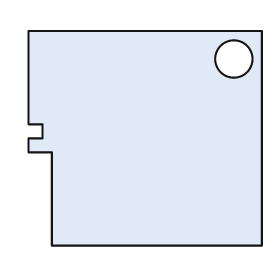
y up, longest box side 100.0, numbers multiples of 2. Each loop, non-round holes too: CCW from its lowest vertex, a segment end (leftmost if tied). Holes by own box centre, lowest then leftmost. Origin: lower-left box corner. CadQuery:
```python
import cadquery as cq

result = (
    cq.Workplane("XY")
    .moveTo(10.0, 0.0)
    .lineTo(100.0, 0.0)
    .lineTo(100.0, 92.0)
    .lineTo(0.0, 92.0)
    .lineTo(0.0, 52.0)
    .lineTo(6.0, 52.0)
    .lineTo(6.0, 46.0)
    .lineTo(0.0, 46.0)
    .lineTo(0.0, 40.0)
    .lineTo(10.0, 40.0)
    .close()
    .moveTo(88.0, 80.0)
    .circle(8.0)
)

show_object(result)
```